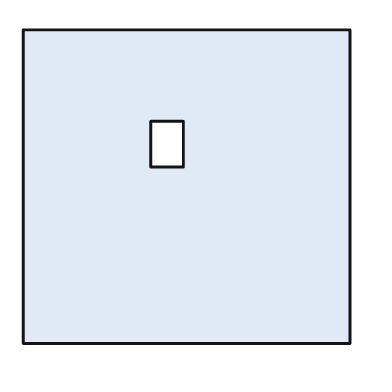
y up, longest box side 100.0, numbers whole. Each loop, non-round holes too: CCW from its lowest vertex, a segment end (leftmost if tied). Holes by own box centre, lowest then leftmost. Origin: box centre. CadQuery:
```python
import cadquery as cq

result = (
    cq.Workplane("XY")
    .moveTo(-50.0, -48.0)
    .lineTo(50.0, -48.0)
    .lineTo(50.0, 48.0)
    .lineTo(-50.0, 48.0)
    .close()
    .moveTo(-11.0, 6.0)
    .lineTo(-1.0, 6.0)
    .lineTo(-1.0, 20.0)
    .lineTo(-11.0, 20.0)
    .close()
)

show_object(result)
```